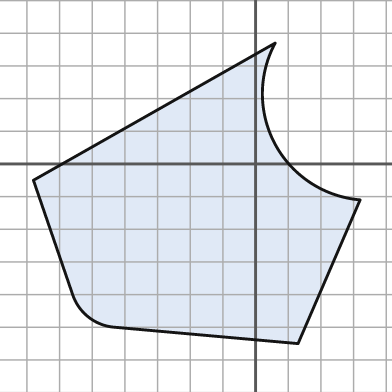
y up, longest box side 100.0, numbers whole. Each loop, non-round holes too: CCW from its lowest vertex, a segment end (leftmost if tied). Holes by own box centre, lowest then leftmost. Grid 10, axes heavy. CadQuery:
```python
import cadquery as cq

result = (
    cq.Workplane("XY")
    .moveTo(13.0, -55.0)
    .lineTo(32.0, -11.0)
    .threePointArc((6.0, 6.0), (6.0, 37.0))
    .lineTo(-68.0, -5.0)
    .lineTo(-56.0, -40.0)
    .threePointArc((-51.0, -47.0), (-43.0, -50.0))
    .close()
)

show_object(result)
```